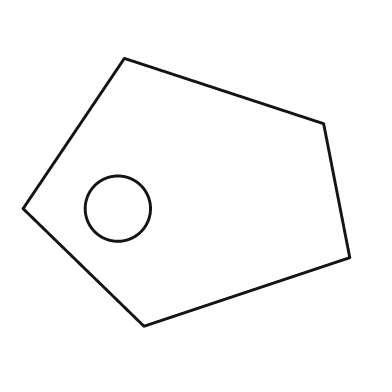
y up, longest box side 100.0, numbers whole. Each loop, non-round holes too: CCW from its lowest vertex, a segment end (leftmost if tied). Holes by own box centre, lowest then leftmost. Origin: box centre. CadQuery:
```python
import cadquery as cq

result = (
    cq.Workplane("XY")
    .moveTo(-13.0, -41.0)
    .lineTo(50.0, -20.0)
    .lineTo(42.0, 21.0)
    .lineTo(-19.0, 41.0)
    .lineTo(-50.0, -5.0)
    .close()
    .moveTo(-21.0, -5.0)
    .circle(10.0)
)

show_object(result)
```